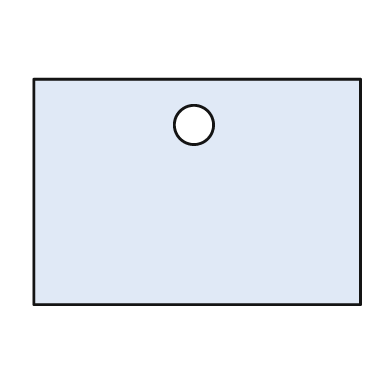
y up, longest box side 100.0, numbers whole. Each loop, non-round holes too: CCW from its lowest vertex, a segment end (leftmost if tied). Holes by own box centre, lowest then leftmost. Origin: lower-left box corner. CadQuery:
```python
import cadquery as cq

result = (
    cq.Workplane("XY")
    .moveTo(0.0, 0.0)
    .lineTo(100.0, 0.0)
    .lineTo(100.0, 69.0)
    .lineTo(0.0, 69.0)
    .close()
    .moveTo(49.0, 55.0)
    .circle(6.0)
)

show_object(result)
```